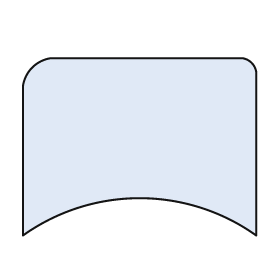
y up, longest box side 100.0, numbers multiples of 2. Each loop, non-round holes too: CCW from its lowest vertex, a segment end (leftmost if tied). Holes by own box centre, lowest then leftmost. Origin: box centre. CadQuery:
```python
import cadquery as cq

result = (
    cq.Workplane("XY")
    .moveTo(-50.0, -38.0)
    .threePointArc((0.0, -22.0), (50.0, -38.0))
    .lineTo(50.0, 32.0)
    .threePointArc((48.0, 36.0), (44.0, 38.0))
    .lineTo(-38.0, 38.0)
    .threePointArc((-46.0, 34.0), (-50.0, 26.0))
    .close()
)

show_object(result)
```